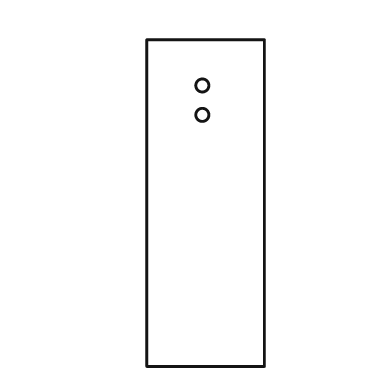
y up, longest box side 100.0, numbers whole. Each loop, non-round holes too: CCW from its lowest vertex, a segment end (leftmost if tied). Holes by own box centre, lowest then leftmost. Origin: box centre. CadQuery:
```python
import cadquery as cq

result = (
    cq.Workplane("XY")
    .moveTo(-18.0, -50.0)
    .lineTo(18.0, -50.0)
    .lineTo(18.0, 50.0)
    .lineTo(-18.0, 50.0)
    .close()
    .moveTo(-1.0, 27.0)
    .circle(2.0)
    .moveTo(-1.0, 36.0)
    .circle(2.0)
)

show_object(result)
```